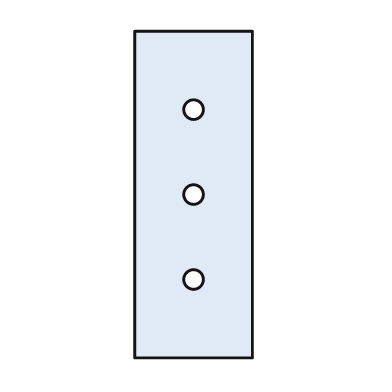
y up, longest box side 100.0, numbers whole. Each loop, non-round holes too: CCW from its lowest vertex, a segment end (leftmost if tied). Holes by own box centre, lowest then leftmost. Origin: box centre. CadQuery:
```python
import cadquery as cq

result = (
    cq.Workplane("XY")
    .moveTo(-18.0, -50.0)
    .lineTo(18.0, -50.0)
    .lineTo(18.0, 50.0)
    .lineTo(-18.0, 50.0)
    .close()
    .moveTo(0.0, -26.0)
    .circle(3.0)
    .moveTo(0.0, 0.0)
    .circle(3.0)
    .moveTo(0.0, 26.0)
    .circle(3.0)
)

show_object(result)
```